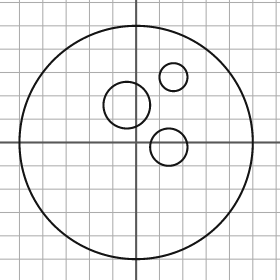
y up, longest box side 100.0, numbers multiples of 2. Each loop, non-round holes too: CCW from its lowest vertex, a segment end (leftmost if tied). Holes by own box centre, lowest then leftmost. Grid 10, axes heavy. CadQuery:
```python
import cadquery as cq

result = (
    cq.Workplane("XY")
    .moveTo(0.0, 0.0)
    .circle(50.0)
    .moveTo(14.0, -2.0)
    .circle(8.0)
    .moveTo(-4.0, 16.0)
    .circle(10.0)
    .moveTo(16.0, 28.0)
    .circle(6.0)
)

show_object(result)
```